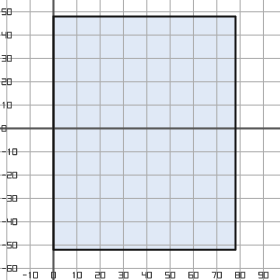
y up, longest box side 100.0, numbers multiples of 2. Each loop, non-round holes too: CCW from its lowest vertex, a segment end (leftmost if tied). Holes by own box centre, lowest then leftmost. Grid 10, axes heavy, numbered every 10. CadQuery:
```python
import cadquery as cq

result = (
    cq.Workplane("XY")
    .moveTo(0.0, -52.0)
    .lineTo(78.0, -52.0)
    .lineTo(78.0, 48.0)
    .lineTo(0.0, 48.0)
    .close()
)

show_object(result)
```